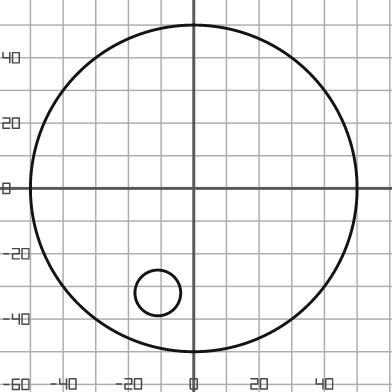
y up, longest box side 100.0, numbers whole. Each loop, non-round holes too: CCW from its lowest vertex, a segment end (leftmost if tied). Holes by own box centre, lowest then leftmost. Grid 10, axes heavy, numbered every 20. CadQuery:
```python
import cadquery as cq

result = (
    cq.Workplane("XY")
    .moveTo(0.0, 0.0)
    .circle(50.0)
    .moveTo(-11.0, -32.0)
    .circle(7.0)
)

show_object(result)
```